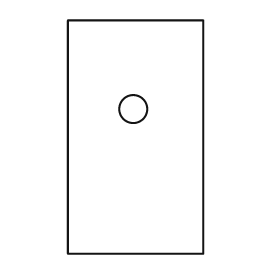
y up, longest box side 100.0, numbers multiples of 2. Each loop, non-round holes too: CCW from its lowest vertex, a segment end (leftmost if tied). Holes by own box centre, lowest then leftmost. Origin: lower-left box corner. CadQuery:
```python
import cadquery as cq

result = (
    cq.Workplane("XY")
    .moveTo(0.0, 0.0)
    .lineTo(58.0, 0.0)
    .lineTo(58.0, 100.0)
    .lineTo(0.0, 100.0)
    .close()
    .moveTo(28.0, 62.0)
    .circle(6.0)
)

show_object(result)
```